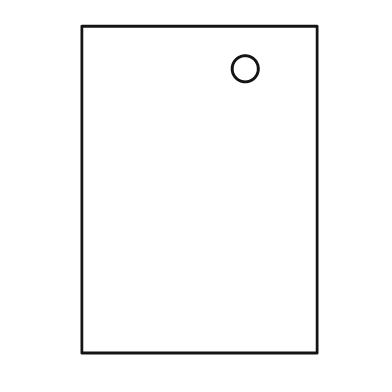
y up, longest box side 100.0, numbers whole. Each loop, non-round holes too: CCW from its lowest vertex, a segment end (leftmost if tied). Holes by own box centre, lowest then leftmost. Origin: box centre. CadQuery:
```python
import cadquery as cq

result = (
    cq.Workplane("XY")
    .moveTo(-36.0, -50.0)
    .lineTo(36.0, -50.0)
    .lineTo(36.0, 50.0)
    .lineTo(-36.0, 50.0)
    .close()
    .moveTo(14.0, 37.0)
    .circle(4.0)
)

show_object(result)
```